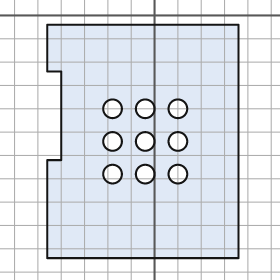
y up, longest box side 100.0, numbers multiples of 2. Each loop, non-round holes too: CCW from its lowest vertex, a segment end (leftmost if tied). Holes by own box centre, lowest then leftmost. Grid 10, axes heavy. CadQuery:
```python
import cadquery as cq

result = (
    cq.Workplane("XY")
    .moveTo(-46.0, -104.0)
    .lineTo(36.0, -104.0)
    .lineTo(36.0, -4.0)
    .lineTo(-46.0, -4.0)
    .lineTo(-46.0, -24.0)
    .lineTo(-40.0, -24.0)
    .lineTo(-40.0, -62.0)
    .lineTo(-46.0, -62.0)
    .close()
    .moveTo(-18.0, -68.0)
    .circle(4.0)
    .moveTo(-4.0, -68.0)
    .circle(4.0)
    .moveTo(10.0, -68.0)
    .circle(4.0)
    .moveTo(-18.0, -54.0)
    .circle(4.0)
    .moveTo(-4.0, -54.0)
    .circle(4.0)
    .moveTo(10.0, -54.0)
    .circle(4.0)
    .moveTo(-18.0, -40.0)
    .circle(4.0)
    .moveTo(-4.0, -40.0)
    .circle(4.0)
    .moveTo(10.0, -40.0)
    .circle(4.0)
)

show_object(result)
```